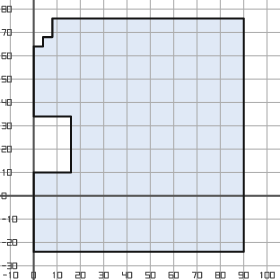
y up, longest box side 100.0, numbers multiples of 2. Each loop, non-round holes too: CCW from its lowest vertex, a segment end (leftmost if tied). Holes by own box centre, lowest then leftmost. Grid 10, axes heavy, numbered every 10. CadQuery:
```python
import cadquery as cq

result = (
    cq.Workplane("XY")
    .moveTo(0.0, -24.0)
    .lineTo(90.0, -24.0)
    .lineTo(90.0, 76.0)
    .lineTo(8.0, 76.0)
    .lineTo(8.0, 68.0)
    .lineTo(4.0, 68.0)
    .lineTo(4.0, 64.0)
    .lineTo(0.0, 64.0)
    .lineTo(0.0, 34.0)
    .lineTo(16.0, 34.0)
    .lineTo(16.0, 10.0)
    .lineTo(0.0, 10.0)
    .close()
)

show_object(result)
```